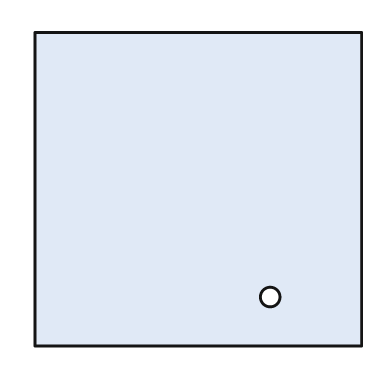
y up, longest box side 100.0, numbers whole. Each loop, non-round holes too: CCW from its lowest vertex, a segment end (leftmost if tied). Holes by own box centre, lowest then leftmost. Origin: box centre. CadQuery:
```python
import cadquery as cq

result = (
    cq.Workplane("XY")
    .moveTo(-50.0, -48.0)
    .lineTo(50.0, -48.0)
    .lineTo(50.0, 48.0)
    .lineTo(-50.0, 48.0)
    .close()
    .moveTo(22.0, -33.0)
    .circle(3.0)
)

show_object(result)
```